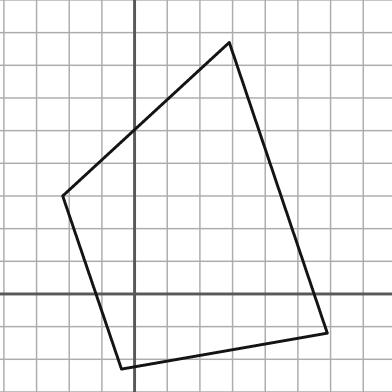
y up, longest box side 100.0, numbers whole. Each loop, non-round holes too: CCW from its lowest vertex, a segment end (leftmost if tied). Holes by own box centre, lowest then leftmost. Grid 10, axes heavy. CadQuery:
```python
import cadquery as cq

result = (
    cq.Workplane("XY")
    .moveTo(-4.0, -23.0)
    .lineTo(59.0, -12.0)
    .lineTo(29.0, 77.0)
    .lineTo(-22.0, 30.0)
    .close()
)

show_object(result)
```